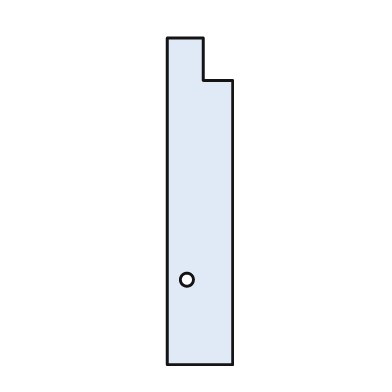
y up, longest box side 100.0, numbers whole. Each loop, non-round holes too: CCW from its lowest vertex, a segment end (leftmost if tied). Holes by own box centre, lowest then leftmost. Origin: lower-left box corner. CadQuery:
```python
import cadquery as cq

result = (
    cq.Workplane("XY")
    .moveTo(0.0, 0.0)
    .lineTo(20.0, 0.0)
    .lineTo(20.0, 87.0)
    .lineTo(11.0, 87.0)
    .lineTo(11.0, 100.0)
    .lineTo(0.0, 100.0)
    .close()
    .moveTo(6.0, 26.0)
    .circle(2.0)
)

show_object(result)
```